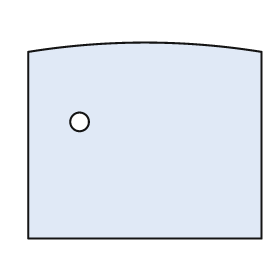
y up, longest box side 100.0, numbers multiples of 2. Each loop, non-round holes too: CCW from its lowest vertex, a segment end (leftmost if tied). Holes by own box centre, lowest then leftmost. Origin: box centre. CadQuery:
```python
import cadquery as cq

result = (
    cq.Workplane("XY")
    .moveTo(-50.0, -42.0)
    .lineTo(50.0, -42.0)
    .lineTo(50.0, 38.0)
    .threePointArc((0.0, 42.0), (-50.0, 38.0))
    .close()
    .moveTo(-28.0, 8.0)
    .circle(4.0)
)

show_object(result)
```